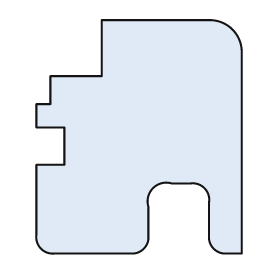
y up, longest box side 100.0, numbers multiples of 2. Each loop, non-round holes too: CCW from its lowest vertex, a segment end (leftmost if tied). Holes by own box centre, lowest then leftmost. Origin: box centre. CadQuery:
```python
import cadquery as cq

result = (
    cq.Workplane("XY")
    .moveTo(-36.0, -50.0)
    .lineTo(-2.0, -50.0)
    .threePointArc((2.0, -48.0), (4.0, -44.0))
    .lineTo(4.0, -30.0)
    .threePointArc((6.0, -22.0), (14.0, -20.0))
    .lineTo(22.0, -20.0)
    .threePointArc((28.0, -22.0), (30.0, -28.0))
    .lineTo(30.0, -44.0)
    .threePointArc((32.0, -48.0), (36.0, -50.0))
    .lineTo(44.0, -50.0)
    .lineTo(44.0, 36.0)
    .threePointArc((40.0, 46.0), (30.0, 50.0))
    .lineTo(-16.0, 50.0)
    .lineTo(-16.0, 26.0)
    .lineTo(-38.0, 26.0)
    .lineTo(-38.0, 14.0)
    .lineTo(-44.0, 14.0)
    .lineTo(-44.0, 4.0)
    .lineTo(-32.0, 4.0)
    .lineTo(-32.0, -12.0)
    .lineTo(-44.0, -12.0)
    .lineTo(-44.0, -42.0)
    .threePointArc((-42.0, -48.0), (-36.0, -50.0))
    .close()
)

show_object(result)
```